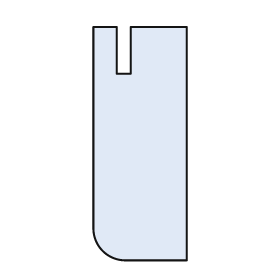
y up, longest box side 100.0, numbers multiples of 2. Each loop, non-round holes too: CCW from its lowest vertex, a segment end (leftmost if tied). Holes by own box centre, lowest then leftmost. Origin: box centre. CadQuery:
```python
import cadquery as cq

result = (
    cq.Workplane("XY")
    .moveTo(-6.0, -50.0)
    .lineTo(20.0, -50.0)
    .lineTo(20.0, 50.0)
    .lineTo(-4.0, 50.0)
    .lineTo(-4.0, 30.0)
    .lineTo(-10.0, 30.0)
    .lineTo(-10.0, 50.0)
    .lineTo(-20.0, 50.0)
    .lineTo(-20.0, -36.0)
    .threePointArc((-16.0, -46.0), (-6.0, -50.0))
    .close()
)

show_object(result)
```